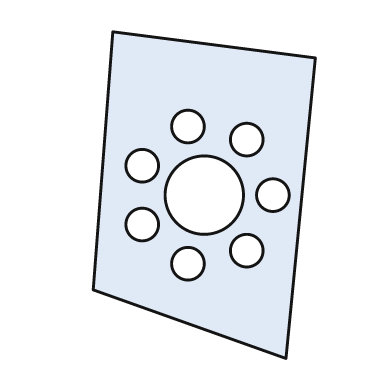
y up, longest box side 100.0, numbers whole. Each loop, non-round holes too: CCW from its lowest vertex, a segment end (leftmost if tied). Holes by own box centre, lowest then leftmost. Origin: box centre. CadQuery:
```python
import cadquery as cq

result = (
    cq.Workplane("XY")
    .moveTo(25.0, -50.0)
    .lineTo(34.0, 42.0)
    .lineTo(-28.0, 50.0)
    .lineTo(-34.0, -29.0)
    .close()
    .moveTo(-5.0, -21.0)
    .circle(5.0)
    .moveTo(13.0, -17.0)
    .circle(5.0)
    .moveTo(-19.0, -9.0)
    .circle(5.0)
    .moveTo(0.0, 0.0)
    .circle(12.0)
    .moveTo(21.0, 0.0)
    .circle(5.0)
    .moveTo(-19.0, 9.0)
    .circle(5.0)
    .moveTo(13.0, 17.0)
    .circle(5.0)
    .moveTo(-5.0, 21.0)
    .circle(5.0)
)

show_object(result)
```